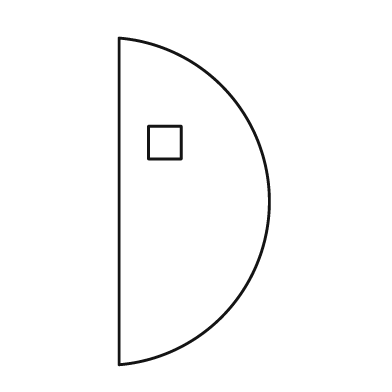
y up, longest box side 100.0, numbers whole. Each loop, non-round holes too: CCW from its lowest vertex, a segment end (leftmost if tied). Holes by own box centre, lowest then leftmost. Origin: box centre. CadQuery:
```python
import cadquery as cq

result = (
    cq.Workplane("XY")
    .moveTo(-23.0, -50.0)
    .threePointArc((23.0, 0.0), (-23.0, 50.0))
    .close()
    .moveTo(-14.0, 13.0)
    .lineTo(-4.0, 13.0)
    .lineTo(-4.0, 23.0)
    .lineTo(-14.0, 23.0)
    .close()
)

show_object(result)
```